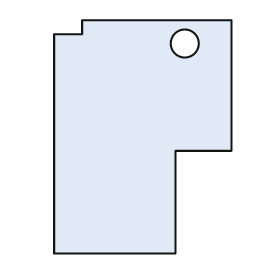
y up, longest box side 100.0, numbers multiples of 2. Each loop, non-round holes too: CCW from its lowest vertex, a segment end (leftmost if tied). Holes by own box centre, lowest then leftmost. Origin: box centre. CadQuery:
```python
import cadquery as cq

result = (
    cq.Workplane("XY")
    .moveTo(-38.0, -50.0)
    .lineTo(14.0, -50.0)
    .lineTo(14.0, -6.0)
    .lineTo(38.0, -6.0)
    .lineTo(38.0, 50.0)
    .lineTo(-26.0, 50.0)
    .lineTo(-26.0, 44.0)
    .lineTo(-38.0, 44.0)
    .close()
    .moveTo(18.0, 40.0)
    .circle(6.0)
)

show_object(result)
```